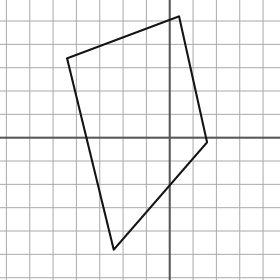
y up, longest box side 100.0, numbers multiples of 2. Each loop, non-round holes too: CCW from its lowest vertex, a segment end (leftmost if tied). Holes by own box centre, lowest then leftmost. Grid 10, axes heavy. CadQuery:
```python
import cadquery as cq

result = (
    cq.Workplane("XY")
    .moveTo(-24.0, -48.0)
    .lineTo(16.0, -2.0)
    .lineTo(4.0, 52.0)
    .lineTo(-44.0, 34.0)
    .close()
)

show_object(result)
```